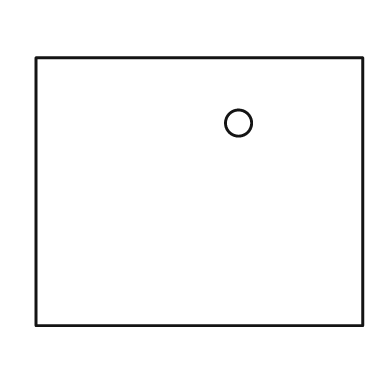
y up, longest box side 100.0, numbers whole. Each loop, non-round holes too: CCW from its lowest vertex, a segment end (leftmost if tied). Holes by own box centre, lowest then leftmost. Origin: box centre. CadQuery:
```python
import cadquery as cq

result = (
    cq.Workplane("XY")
    .moveTo(-50.0, -41.0)
    .lineTo(50.0, -41.0)
    .lineTo(50.0, 41.0)
    .lineTo(-50.0, 41.0)
    .close()
    .moveTo(12.0, 21.0)
    .circle(4.0)
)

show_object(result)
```